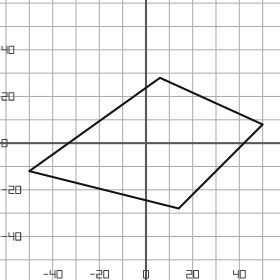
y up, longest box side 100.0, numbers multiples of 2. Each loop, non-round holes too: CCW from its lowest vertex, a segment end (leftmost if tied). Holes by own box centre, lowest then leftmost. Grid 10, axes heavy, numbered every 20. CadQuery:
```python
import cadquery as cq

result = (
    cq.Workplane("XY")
    .moveTo(14.0, -28.0)
    .lineTo(50.0, 8.0)
    .lineTo(6.0, 28.0)
    .lineTo(-50.0, -12.0)
    .close()
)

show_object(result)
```